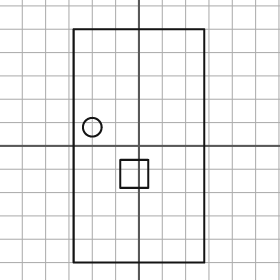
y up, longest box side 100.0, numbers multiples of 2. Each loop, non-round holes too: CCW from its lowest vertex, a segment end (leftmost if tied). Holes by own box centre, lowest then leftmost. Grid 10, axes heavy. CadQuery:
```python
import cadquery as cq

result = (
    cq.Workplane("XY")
    .moveTo(-28.0, -50.0)
    .lineTo(28.0, -50.0)
    .lineTo(28.0, 50.0)
    .lineTo(-28.0, 50.0)
    .close()
    .moveTo(-8.0, -18.0)
    .lineTo(4.0, -18.0)
    .lineTo(4.0, -6.0)
    .lineTo(-8.0, -6.0)
    .close()
    .moveTo(-20.0, 8.0)
    .circle(4.0)
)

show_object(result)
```